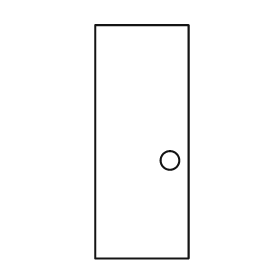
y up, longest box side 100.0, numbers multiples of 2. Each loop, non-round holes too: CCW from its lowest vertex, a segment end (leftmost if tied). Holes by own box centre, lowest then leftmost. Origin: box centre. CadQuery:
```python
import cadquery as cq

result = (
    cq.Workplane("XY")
    .moveTo(-20.0, -50.0)
    .lineTo(20.0, -50.0)
    .lineTo(20.0, 50.0)
    .lineTo(-20.0, 50.0)
    .close()
    .moveTo(12.0, -8.0)
    .circle(4.0)
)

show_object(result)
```